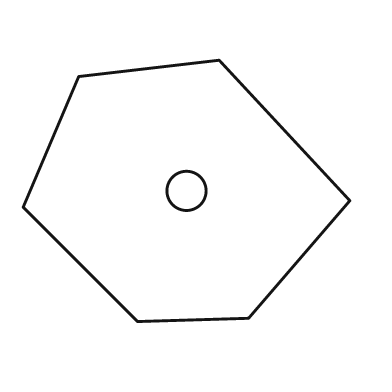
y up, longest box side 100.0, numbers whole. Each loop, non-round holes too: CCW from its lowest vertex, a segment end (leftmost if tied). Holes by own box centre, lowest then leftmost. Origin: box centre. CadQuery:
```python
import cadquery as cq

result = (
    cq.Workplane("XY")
    .moveTo(-15.0, -40.0)
    .lineTo(19.0, -39.0)
    .lineTo(50.0, -3.0)
    .lineTo(10.0, 40.0)
    .lineTo(-33.0, 35.0)
    .lineTo(-50.0, -5.0)
    .close()
    .moveTo(0.0, 0.0)
    .circle(6.0)
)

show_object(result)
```